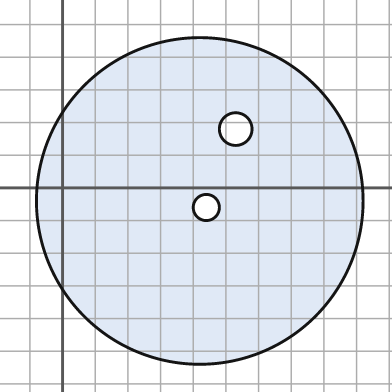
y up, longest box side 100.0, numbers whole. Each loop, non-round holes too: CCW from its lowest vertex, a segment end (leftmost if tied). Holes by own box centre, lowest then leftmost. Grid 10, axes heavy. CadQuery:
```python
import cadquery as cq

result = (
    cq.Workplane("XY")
    .moveTo(42.0, -4.0)
    .circle(50.0)
    .moveTo(44.0, -6.0)
    .circle(4.0)
    .moveTo(53.0, 18.0)
    .circle(5.0)
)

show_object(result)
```